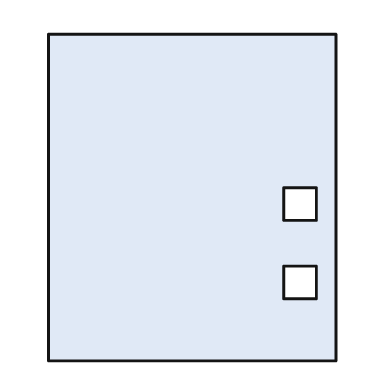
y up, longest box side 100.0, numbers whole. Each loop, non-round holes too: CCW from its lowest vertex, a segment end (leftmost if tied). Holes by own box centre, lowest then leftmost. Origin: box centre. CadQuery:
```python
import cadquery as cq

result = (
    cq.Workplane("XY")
    .moveTo(-44.0, -50.0)
    .lineTo(44.0, -50.0)
    .lineTo(44.0, 50.0)
    .lineTo(-44.0, 50.0)
    .close()
    .moveTo(28.0, -31.0)
    .lineTo(38.0, -31.0)
    .lineTo(38.0, -21.0)
    .lineTo(28.0, -21.0)
    .close()
    .moveTo(28.0, -7.0)
    .lineTo(38.0, -7.0)
    .lineTo(38.0, 3.0)
    .lineTo(28.0, 3.0)
    .close()
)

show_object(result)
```